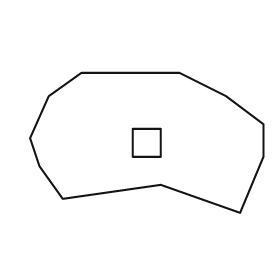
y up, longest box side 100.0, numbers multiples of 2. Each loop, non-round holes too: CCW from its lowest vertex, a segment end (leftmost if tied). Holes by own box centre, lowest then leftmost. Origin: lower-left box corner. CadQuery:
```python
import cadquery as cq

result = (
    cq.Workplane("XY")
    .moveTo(90.0, 0.0)
    .lineTo(100.0, 24.0)
    .lineTo(100.0, 38.0)
    .lineTo(84.0, 50.0)
    .lineTo(64.0, 60.0)
    .lineTo(22.0, 60.0)
    .lineTo(8.0, 50.0)
    .lineTo(0.0, 32.0)
    .lineTo(4.0, 20.0)
    .lineTo(14.0, 6.0)
    .lineTo(56.0, 12.0)
    .close()
    .moveTo(44.0, 24.0)
    .lineTo(56.0, 24.0)
    .lineTo(56.0, 36.0)
    .lineTo(44.0, 36.0)
    .close()
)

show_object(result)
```